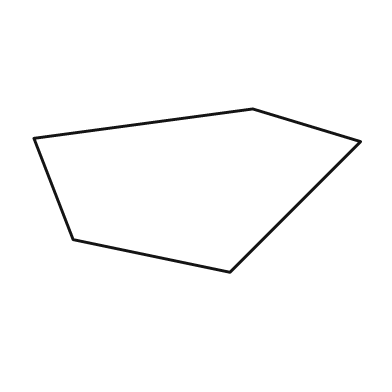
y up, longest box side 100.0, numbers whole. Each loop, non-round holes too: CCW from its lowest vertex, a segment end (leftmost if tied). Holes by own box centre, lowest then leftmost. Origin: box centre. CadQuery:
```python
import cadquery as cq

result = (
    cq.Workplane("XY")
    .moveTo(10.0, -25.0)
    .lineTo(50.0, 15.0)
    .lineTo(17.0, 25.0)
    .lineTo(-50.0, 16.0)
    .lineTo(-38.0, -15.0)
    .close()
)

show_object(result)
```